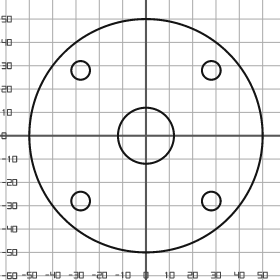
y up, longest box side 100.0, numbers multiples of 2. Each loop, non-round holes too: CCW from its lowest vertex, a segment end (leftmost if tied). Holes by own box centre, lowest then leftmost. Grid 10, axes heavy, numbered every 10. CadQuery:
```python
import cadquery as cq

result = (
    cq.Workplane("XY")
    .moveTo(0.0, 0.0)
    .circle(50.0)
    .moveTo(-28.0, -28.0)
    .circle(4.0)
    .moveTo(28.0, -28.0)
    .circle(4.0)
    .moveTo(0.0, 0.0)
    .circle(12.0)
    .moveTo(-28.0, 28.0)
    .circle(4.0)
    .moveTo(28.0, 28.0)
    .circle(4.0)
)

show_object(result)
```